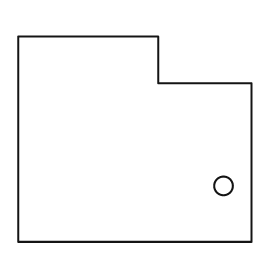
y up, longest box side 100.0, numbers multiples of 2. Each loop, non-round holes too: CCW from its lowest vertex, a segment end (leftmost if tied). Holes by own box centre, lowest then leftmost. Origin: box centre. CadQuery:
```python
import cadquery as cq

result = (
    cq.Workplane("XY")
    .moveTo(-50.0, -44.0)
    .lineTo(50.0, -44.0)
    .lineTo(50.0, 24.0)
    .lineTo(10.0, 24.0)
    .lineTo(10.0, 44.0)
    .lineTo(-50.0, 44.0)
    .close()
    .moveTo(38.0, -20.0)
    .circle(4.0)
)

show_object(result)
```